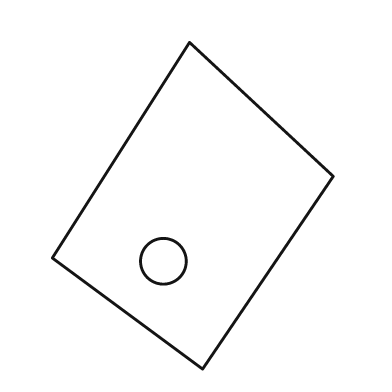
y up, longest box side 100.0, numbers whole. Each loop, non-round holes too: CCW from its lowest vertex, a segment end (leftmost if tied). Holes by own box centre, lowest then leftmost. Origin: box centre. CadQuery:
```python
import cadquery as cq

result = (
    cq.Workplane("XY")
    .moveTo(3.0, -50.0)
    .lineTo(43.0, 9.0)
    .lineTo(-1.0, 50.0)
    .lineTo(-43.0, -16.0)
    .close()
    .moveTo(-9.0, -17.0)
    .circle(7.0)
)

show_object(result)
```